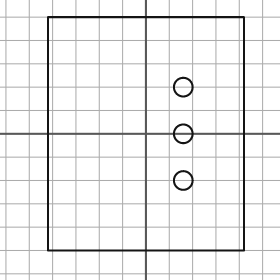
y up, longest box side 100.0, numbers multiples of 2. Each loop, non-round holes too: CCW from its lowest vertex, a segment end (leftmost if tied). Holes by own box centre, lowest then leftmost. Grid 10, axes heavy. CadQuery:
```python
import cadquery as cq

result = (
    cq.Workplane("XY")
    .moveTo(-42.0, -50.0)
    .lineTo(42.0, -50.0)
    .lineTo(42.0, 50.0)
    .lineTo(-42.0, 50.0)
    .close()
    .moveTo(16.0, -20.0)
    .circle(4.0)
    .moveTo(16.0, 0.0)
    .circle(4.0)
    .moveTo(16.0, 20.0)
    .circle(4.0)
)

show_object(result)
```